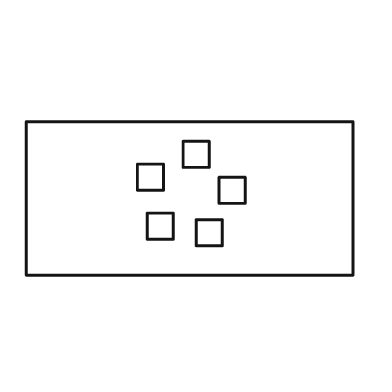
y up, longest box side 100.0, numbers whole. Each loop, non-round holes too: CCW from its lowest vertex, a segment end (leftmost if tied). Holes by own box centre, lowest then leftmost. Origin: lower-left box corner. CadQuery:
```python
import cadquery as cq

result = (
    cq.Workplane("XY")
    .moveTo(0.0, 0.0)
    .lineTo(100.0, 0.0)
    .lineTo(100.0, 47.0)
    .lineTo(0.0, 47.0)
    .close()
    .moveTo(52.0, 9.0)
    .lineTo(60.0, 9.0)
    .lineTo(60.0, 17.0)
    .lineTo(52.0, 17.0)
    .close()
    .moveTo(37.0, 11.0)
    .lineTo(45.0, 11.0)
    .lineTo(45.0, 19.0)
    .lineTo(37.0, 19.0)
    .close()
    .moveTo(59.0, 22.0)
    .lineTo(67.0, 22.0)
    .lineTo(67.0, 30.0)
    .lineTo(59.0, 30.0)
    .close()
    .moveTo(34.0, 26.0)
    .lineTo(42.0, 26.0)
    .lineTo(42.0, 34.0)
    .lineTo(34.0, 34.0)
    .close()
    .moveTo(48.0, 33.0)
    .lineTo(56.0, 33.0)
    .lineTo(56.0, 41.0)
    .lineTo(48.0, 41.0)
    .close()
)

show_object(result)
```